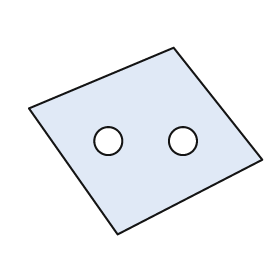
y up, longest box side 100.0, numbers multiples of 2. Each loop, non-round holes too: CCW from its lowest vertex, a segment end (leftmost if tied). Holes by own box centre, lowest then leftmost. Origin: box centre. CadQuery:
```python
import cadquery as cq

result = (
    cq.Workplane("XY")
    .moveTo(-12.0, -40.0)
    .lineTo(50.0, -8.0)
    .lineTo(12.0, 40.0)
    .lineTo(-50.0, 14.0)
    .close()
    .moveTo(-16.0, 0.0)
    .circle(6.0)
    .moveTo(16.0, 0.0)
    .circle(6.0)
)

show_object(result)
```